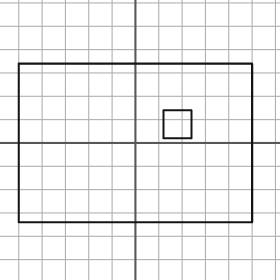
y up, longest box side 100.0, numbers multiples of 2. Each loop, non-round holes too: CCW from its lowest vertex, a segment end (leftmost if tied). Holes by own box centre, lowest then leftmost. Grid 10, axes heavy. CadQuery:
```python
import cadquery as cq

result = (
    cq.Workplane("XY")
    .moveTo(-50.0, -34.0)
    .lineTo(50.0, -34.0)
    .lineTo(50.0, 34.0)
    .lineTo(-50.0, 34.0)
    .close()
    .moveTo(12.0, 2.0)
    .lineTo(24.0, 2.0)
    .lineTo(24.0, 14.0)
    .lineTo(12.0, 14.0)
    .close()
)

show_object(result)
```